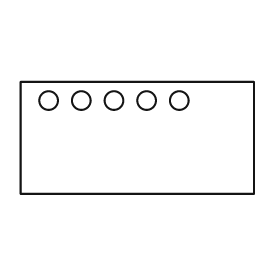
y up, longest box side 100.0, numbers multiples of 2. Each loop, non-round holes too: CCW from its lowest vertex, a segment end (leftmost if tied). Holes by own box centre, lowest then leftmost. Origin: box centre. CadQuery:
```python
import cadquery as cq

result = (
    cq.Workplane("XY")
    .moveTo(-50.0, -24.0)
    .lineTo(50.0, -24.0)
    .lineTo(50.0, 24.0)
    .lineTo(-50.0, 24.0)
    .close()
    .moveTo(-38.0, 16.0)
    .circle(4.0)
    .moveTo(-24.0, 16.0)
    .circle(4.0)
    .moveTo(-10.0, 16.0)
    .circle(4.0)
    .moveTo(4.0, 16.0)
    .circle(4.0)
    .moveTo(18.0, 16.0)
    .circle(4.0)
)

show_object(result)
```